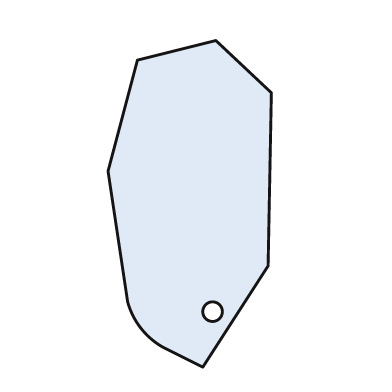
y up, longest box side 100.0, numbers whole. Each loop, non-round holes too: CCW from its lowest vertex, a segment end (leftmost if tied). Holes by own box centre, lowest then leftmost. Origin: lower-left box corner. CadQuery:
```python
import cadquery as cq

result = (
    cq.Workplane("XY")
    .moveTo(29.0, 0.0)
    .lineTo(49.0, 31.0)
    .lineTo(50.0, 84.0)
    .lineTo(33.0, 100.0)
    .lineTo(9.0, 94.0)
    .lineTo(0.0, 60.0)
    .lineTo(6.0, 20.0)
    .threePointArc((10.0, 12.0), (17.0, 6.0))
    .close()
    .moveTo(32.0, 17.0)
    .circle(3.0)
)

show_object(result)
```